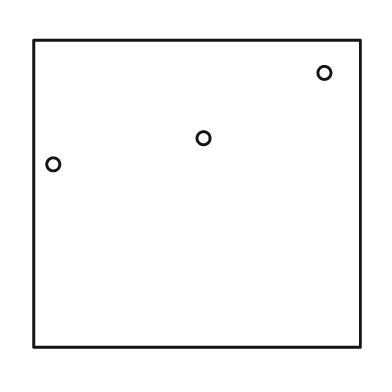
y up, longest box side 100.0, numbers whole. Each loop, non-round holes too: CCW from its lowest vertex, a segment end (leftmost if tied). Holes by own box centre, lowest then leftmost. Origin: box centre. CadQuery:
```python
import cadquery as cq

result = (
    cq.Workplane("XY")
    .moveTo(-50.0, -47.0)
    .lineTo(50.0, -47.0)
    .lineTo(50.0, 47.0)
    .lineTo(-50.0, 47.0)
    .close()
    .moveTo(-44.0, 9.0)
    .circle(2.0)
    .moveTo(2.0, 17.0)
    .circle(2.0)
    .moveTo(39.0, 37.0)
    .circle(2.0)
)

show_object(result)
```